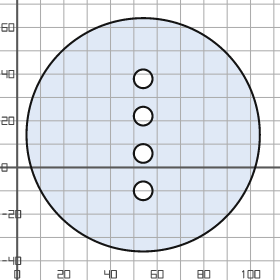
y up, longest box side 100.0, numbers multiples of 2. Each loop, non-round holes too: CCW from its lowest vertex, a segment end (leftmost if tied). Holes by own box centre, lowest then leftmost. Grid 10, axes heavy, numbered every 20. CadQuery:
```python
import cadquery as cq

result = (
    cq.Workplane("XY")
    .moveTo(54.0, 14.0)
    .circle(50.0)
    .moveTo(54.0, -10.0)
    .circle(4.0)
    .moveTo(54.0, 6.0)
    .circle(4.0)
    .moveTo(54.0, 22.0)
    .circle(4.0)
    .moveTo(54.0, 38.0)
    .circle(4.0)
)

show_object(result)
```